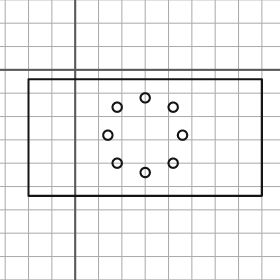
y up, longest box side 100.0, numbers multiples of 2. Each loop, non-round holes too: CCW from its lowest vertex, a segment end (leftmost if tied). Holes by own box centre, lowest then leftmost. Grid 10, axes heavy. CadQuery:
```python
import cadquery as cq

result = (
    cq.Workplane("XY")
    .moveTo(-20.0, -54.0)
    .lineTo(80.0, -54.0)
    .lineTo(80.0, -4.0)
    .lineTo(-20.0, -4.0)
    .close()
    .moveTo(30.0, -44.0)
    .circle(2.0)
    .moveTo(18.0, -40.0)
    .circle(2.0)
    .moveTo(42.0, -40.0)
    .circle(2.0)
    .moveTo(14.0, -28.0)
    .circle(2.0)
    .moveTo(46.0, -28.0)
    .circle(2.0)
    .moveTo(18.0, -16.0)
    .circle(2.0)
    .moveTo(42.0, -16.0)
    .circle(2.0)
    .moveTo(30.0, -12.0)
    .circle(2.0)
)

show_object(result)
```